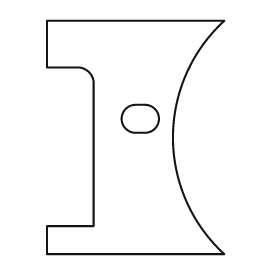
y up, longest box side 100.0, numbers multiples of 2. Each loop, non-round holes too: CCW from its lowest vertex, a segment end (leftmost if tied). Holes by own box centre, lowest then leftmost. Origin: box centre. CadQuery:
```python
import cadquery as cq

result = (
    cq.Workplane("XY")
    .moveTo(-38.0, -50.0)
    .lineTo(38.0, -50.0)
    .threePointArc((16.0, 0.0), (38.0, 50.0))
    .lineTo(-38.0, 50.0)
    .lineTo(-38.0, 30.0)
    .lineTo(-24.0, 30.0)
    .threePointArc((-20.0, 28.0), (-18.0, 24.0))
    .lineTo(-18.0, -38.0)
    .lineTo(-38.0, -38.0)
    .close()
    .moveTo(0.0, 2.0)
    .lineTo(4.0, 2.0)
    .threePointArc((10.0, 8.0), (4.0, 14.0))
    .lineTo(0.0, 14.0)
    .threePointArc((-6.0, 8.0), (0.0, 2.0))
    .close()
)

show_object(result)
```